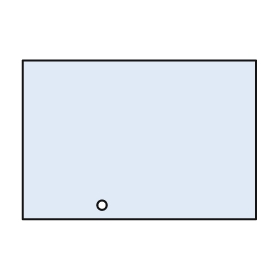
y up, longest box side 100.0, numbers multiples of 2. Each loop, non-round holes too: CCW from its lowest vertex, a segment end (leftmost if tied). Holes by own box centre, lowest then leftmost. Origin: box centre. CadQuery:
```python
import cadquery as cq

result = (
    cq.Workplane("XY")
    .moveTo(-50.0, -34.0)
    .lineTo(50.0, -34.0)
    .lineTo(50.0, 34.0)
    .lineTo(-50.0, 34.0)
    .close()
    .moveTo(-16.0, -28.0)
    .circle(2.0)
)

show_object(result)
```